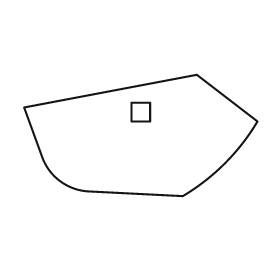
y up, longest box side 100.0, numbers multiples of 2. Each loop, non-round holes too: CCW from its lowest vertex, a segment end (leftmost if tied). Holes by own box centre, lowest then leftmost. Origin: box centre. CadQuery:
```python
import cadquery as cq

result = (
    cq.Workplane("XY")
    .moveTo(18.0, -26.0)
    .threePointArc((36.0, -12.0), (50.0, 6.0))
    .lineTo(24.0, 26.0)
    .lineTo(-50.0, 12.0)
    .lineTo(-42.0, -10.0)
    .threePointArc((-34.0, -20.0), (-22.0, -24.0))
    .close()
    .moveTo(-4.0, 6.0)
    .lineTo(4.0, 6.0)
    .lineTo(4.0, 14.0)
    .lineTo(-4.0, 14.0)
    .close()
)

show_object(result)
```